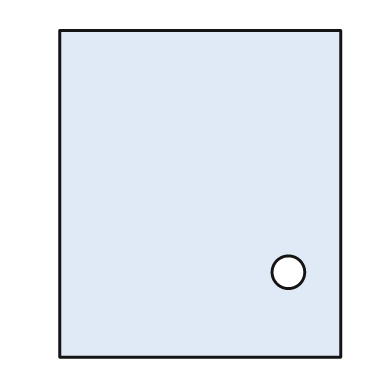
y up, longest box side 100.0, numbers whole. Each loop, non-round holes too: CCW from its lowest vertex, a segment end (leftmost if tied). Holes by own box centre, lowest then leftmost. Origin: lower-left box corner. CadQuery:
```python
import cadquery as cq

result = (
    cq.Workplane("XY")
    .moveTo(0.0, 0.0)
    .lineTo(86.0, 0.0)
    .lineTo(86.0, 100.0)
    .lineTo(0.0, 100.0)
    .close()
    .moveTo(70.0, 26.0)
    .circle(5.0)
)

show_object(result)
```